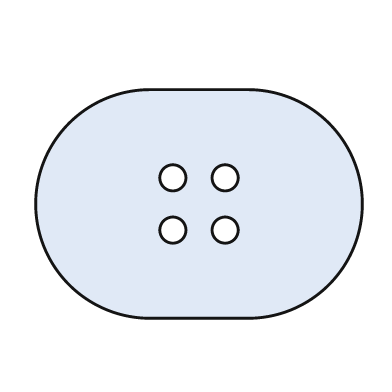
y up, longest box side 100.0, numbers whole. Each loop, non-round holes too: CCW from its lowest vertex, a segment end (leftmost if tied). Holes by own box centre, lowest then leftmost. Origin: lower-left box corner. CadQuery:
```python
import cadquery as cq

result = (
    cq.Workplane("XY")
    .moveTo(35.0, 0.0)
    .lineTo(65.0, 0.0)
    .threePointArc((100.0, 35.0), (65.0, 70.0))
    .lineTo(35.0, 70.0)
    .threePointArc((0.0, 35.0), (35.0, 0.0))
    .close()
    .moveTo(42.0, 27.0)
    .circle(4.0)
    .moveTo(58.0, 27.0)
    .circle(4.0)
    .moveTo(42.0, 43.0)
    .circle(4.0)
    .moveTo(58.0, 43.0)
    .circle(4.0)
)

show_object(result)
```